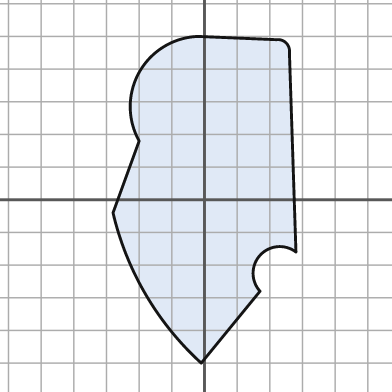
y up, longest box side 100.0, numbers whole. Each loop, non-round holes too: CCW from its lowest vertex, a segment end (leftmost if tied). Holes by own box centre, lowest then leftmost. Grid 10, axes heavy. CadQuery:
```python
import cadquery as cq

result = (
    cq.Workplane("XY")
    .moveTo(-1.0, -50.0)
    .lineTo(17.0, -28.0)
    .threePointArc((17.0, -17.0), (28.0, -16.0))
    .lineTo(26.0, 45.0)
    .threePointArc((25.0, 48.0), (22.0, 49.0))
    .lineTo(-2.0, 50.0)
    .threePointArc((-20.0, 39.0), (-20.0, 18.0))
    .lineTo(-28.0, -4.0)
    .threePointArc((-18.0, -29.0), (-1.0, -50.0))
    .close()
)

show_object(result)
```